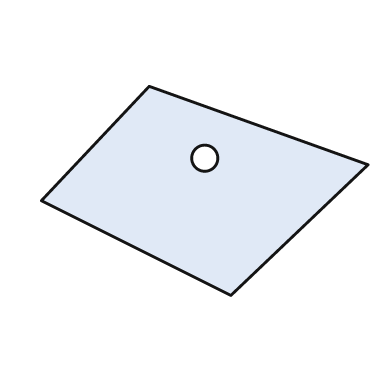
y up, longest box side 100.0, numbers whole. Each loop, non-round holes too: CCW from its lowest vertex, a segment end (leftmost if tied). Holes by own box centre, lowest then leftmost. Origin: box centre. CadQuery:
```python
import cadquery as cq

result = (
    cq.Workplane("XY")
    .moveTo(8.0, -32.0)
    .lineTo(50.0, 8.0)
    .lineTo(-17.0, 32.0)
    .lineTo(-50.0, -3.0)
    .close()
    .moveTo(0.0, 10.0)
    .circle(4.0)
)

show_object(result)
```